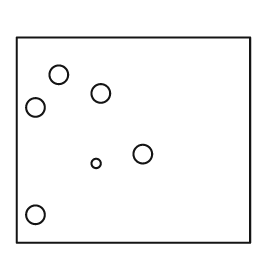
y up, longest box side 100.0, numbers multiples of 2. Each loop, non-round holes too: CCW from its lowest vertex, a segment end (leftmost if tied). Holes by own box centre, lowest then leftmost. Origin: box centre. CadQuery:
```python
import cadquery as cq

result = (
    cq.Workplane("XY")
    .moveTo(-50.0, -44.0)
    .lineTo(50.0, -44.0)
    .lineTo(50.0, 44.0)
    .lineTo(-50.0, 44.0)
    .close()
    .moveTo(-42.0, -32.0)
    .circle(4.0)
    .moveTo(-16.0, -10.0)
    .circle(2.0)
    .moveTo(4.0, -6.0)
    .circle(4.0)
    .moveTo(-42.0, 14.0)
    .circle(4.0)
    .moveTo(-14.0, 20.0)
    .circle(4.0)
    .moveTo(-32.0, 28.0)
    .circle(4.0)
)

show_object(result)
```